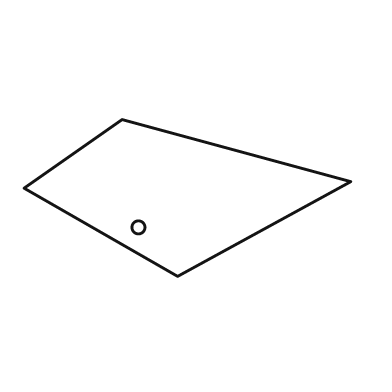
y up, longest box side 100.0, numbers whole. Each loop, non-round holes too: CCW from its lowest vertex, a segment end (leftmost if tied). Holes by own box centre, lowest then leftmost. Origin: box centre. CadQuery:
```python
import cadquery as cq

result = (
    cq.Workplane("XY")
    .moveTo(-3.0, -24.0)
    .lineTo(50.0, 5.0)
    .lineTo(-20.0, 24.0)
    .lineTo(-50.0, 3.0)
    .close()
    .moveTo(-15.0, -9.0)
    .circle(2.0)
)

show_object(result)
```